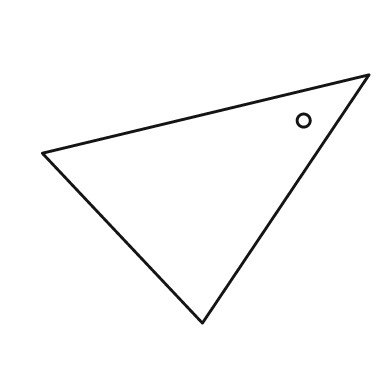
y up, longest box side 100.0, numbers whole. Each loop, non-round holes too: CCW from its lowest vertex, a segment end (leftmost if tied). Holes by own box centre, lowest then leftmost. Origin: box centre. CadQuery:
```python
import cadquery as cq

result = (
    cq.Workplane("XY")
    .moveTo(-1.0, -38.0)
    .lineTo(50.0, 38.0)
    .lineTo(-50.0, 14.0)
    .close()
    .moveTo(30.0, 24.0)
    .circle(2.0)
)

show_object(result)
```